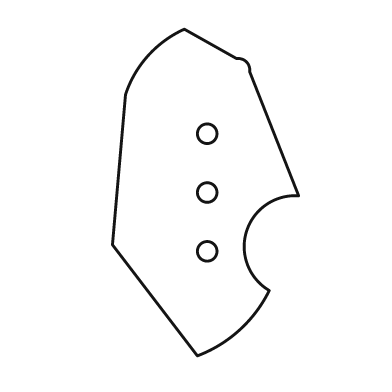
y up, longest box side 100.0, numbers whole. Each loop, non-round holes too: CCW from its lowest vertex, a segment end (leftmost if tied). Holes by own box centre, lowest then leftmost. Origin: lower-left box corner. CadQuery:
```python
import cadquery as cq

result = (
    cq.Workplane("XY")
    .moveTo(26.0, 0.0)
    .threePointArc((39.0, 8.0), (48.0, 20.0))
    .threePointArc((41.0, 38.0), (57.0, 49.0))
    .lineTo(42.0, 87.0)
    .threePointArc((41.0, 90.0), (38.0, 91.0))
    .lineTo(22.0, 100.0)
    .threePointArc((11.0, 92.0), (4.0, 80.0))
    .lineTo(0.0, 34.0)
    .close()
    .moveTo(29.0, 32.0)
    .circle(3.0)
    .moveTo(29.0, 50.0)
    .circle(3.0)
    .moveTo(29.0, 68.0)
    .circle(3.0)
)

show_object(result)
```